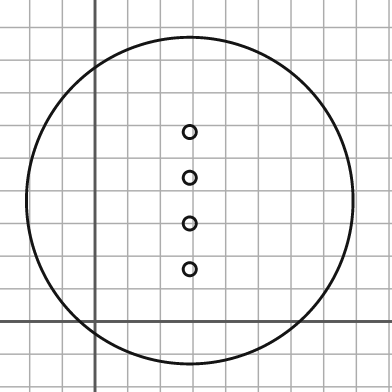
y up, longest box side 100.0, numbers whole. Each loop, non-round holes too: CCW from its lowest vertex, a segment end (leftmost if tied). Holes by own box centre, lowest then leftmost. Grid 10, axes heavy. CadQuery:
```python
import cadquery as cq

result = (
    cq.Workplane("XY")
    .moveTo(29.0, 37.0)
    .circle(50.0)
    .moveTo(29.0, 16.0)
    .circle(2.0)
    .moveTo(29.0, 30.0)
    .circle(2.0)
    .moveTo(29.0, 44.0)
    .circle(2.0)
    .moveTo(29.0, 58.0)
    .circle(2.0)
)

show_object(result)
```